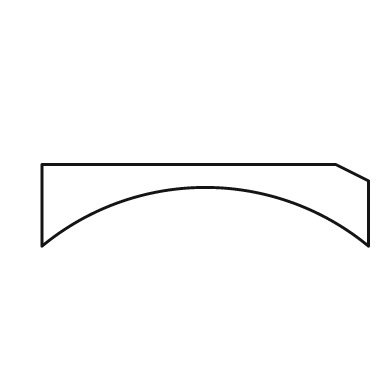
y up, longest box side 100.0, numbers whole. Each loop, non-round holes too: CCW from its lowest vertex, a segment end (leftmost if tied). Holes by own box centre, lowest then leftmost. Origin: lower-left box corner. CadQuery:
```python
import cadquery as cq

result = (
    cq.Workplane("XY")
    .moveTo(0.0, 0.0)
    .threePointArc((50.0, 18.0), (100.0, 0.0))
    .lineTo(100.0, 20.0)
    .lineTo(90.0, 25.0)
    .lineTo(0.0, 25.0)
    .close()
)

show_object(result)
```